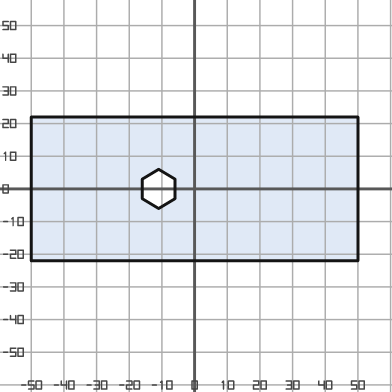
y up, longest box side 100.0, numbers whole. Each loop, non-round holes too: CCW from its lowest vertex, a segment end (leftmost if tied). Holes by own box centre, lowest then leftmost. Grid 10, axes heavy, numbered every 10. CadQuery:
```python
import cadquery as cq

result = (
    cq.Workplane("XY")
    .moveTo(-50.0, -22.0)
    .lineTo(50.0, -22.0)
    .lineTo(50.0, 22.0)
    .lineTo(-50.0, 22.0)
    .close()
    .moveTo(-11.0, -6.0)
    .lineTo(-6.0, -3.0)
    .lineTo(-6.0, 3.0)
    .lineTo(-11.0, 6.0)
    .lineTo(-16.0, 3.0)
    .lineTo(-16.0, -3.0)
    .close()
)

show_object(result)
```